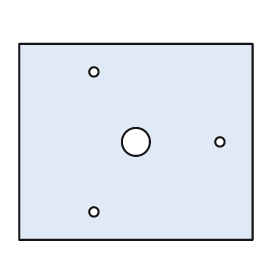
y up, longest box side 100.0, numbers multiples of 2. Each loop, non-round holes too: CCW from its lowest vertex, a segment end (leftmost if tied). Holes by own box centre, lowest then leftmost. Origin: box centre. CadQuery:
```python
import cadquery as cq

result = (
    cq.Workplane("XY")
    .moveTo(-50.0, -42.0)
    .lineTo(50.0, -42.0)
    .lineTo(50.0, 42.0)
    .lineTo(-50.0, 42.0)
    .close()
    .moveTo(-18.0, -30.0)
    .circle(2.0)
    .moveTo(0.0, 0.0)
    .circle(6.0)
    .moveTo(36.0, 0.0)
    .circle(2.0)
    .moveTo(-18.0, 30.0)
    .circle(2.0)
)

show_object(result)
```